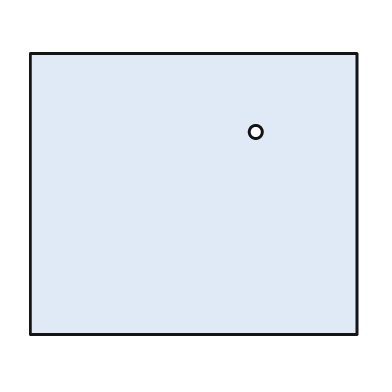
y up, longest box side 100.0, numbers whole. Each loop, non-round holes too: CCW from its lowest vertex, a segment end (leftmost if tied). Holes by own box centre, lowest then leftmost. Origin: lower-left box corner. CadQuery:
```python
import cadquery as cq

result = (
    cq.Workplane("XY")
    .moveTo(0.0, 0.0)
    .lineTo(100.0, 0.0)
    .lineTo(100.0, 86.0)
    .lineTo(0.0, 86.0)
    .close()
    .moveTo(69.0, 62.0)
    .circle(2.0)
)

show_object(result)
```